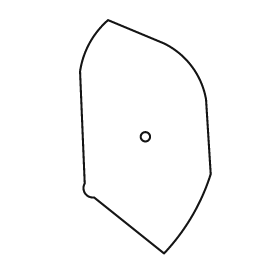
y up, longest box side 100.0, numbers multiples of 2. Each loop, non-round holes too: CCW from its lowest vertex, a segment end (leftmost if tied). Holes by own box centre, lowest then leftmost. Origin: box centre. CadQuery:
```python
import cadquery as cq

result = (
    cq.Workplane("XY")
    .moveTo(8.0, -50.0)
    .threePointArc((20.0, -34.0), (28.0, -16.0))
    .lineTo(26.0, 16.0)
    .threePointArc((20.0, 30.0), (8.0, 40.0))
    .lineTo(-16.0, 50.0)
    .threePointArc((-24.0, 40.0), (-28.0, 28.0))
    .lineTo(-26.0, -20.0)
    .threePointArc((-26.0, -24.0), (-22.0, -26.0))
    .close()
    .moveTo(0.0, 0.0)
    .circle(2.0)
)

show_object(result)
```